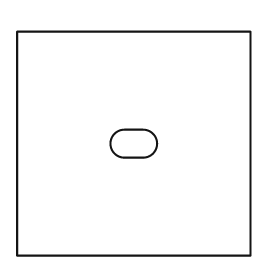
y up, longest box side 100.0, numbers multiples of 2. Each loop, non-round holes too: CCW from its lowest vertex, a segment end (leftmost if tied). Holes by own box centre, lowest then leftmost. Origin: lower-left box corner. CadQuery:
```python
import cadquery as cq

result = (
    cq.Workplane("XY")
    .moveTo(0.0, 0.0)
    .lineTo(100.0, 0.0)
    .lineTo(100.0, 96.0)
    .lineTo(0.0, 96.0)
    .close()
    .moveTo(46.0, 42.0)
    .lineTo(54.0, 42.0)
    .threePointArc((60.0, 48.0), (54.0, 54.0))
    .lineTo(46.0, 54.0)
    .threePointArc((40.0, 48.0), (46.0, 42.0))
    .close()
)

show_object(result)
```